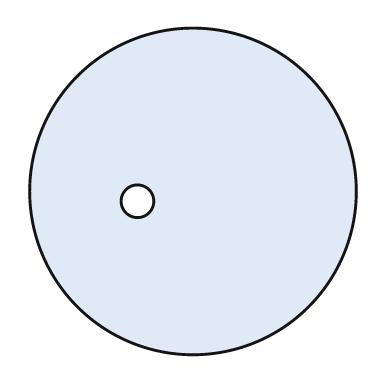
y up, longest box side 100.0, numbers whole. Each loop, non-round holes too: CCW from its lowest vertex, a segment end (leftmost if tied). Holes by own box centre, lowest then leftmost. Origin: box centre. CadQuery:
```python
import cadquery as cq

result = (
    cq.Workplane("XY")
    .moveTo(0.0, 0.0)
    .circle(50.0)
    .moveTo(-17.0, -3.0)
    .circle(5.0)
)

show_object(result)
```